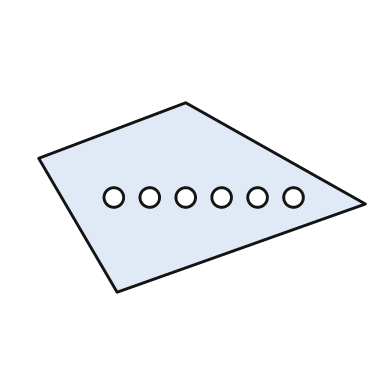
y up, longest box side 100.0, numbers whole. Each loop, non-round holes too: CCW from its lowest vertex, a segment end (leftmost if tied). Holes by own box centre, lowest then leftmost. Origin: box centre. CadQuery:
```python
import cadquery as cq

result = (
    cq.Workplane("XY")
    .moveTo(-26.0, -29.0)
    .lineTo(50.0, -2.0)
    .lineTo(-5.0, 29.0)
    .lineTo(-50.0, 12.0)
    .close()
    .moveTo(-27.0, 0.0)
    .circle(3.0)
    .moveTo(-16.0, 0.0)
    .circle(3.0)
    .moveTo(-5.0, 0.0)
    .circle(3.0)
    .moveTo(6.0, 0.0)
    .circle(3.0)
    .moveTo(17.0, 0.0)
    .circle(3.0)
    .moveTo(28.0, 0.0)
    .circle(3.0)
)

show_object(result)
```